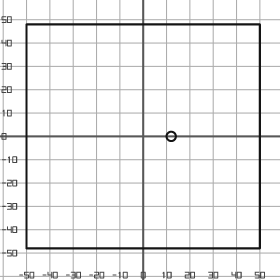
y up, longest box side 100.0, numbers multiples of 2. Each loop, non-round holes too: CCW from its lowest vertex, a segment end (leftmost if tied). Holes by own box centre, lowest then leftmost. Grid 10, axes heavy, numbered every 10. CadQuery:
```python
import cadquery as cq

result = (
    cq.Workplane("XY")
    .moveTo(-50.0, -48.0)
    .lineTo(50.0, -48.0)
    .lineTo(50.0, 48.0)
    .lineTo(-50.0, 48.0)
    .close()
    .moveTo(12.0, 0.0)
    .circle(2.0)
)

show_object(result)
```